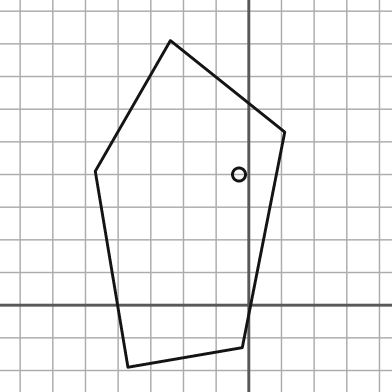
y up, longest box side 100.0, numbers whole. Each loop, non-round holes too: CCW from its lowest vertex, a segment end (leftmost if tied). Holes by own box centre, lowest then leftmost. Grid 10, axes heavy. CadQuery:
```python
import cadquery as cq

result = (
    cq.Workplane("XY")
    .moveTo(-37.0, -19.0)
    .lineTo(-2.0, -13.0)
    .lineTo(11.0, 53.0)
    .lineTo(-24.0, 81.0)
    .lineTo(-47.0, 41.0)
    .close()
    .moveTo(-3.0, 40.0)
    .circle(2.0)
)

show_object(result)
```